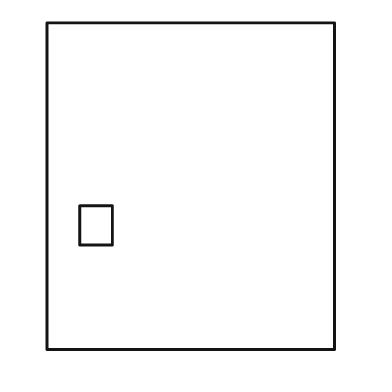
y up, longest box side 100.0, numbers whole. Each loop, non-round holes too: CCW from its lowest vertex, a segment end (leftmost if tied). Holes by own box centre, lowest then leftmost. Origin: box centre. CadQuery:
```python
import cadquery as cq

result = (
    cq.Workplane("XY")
    .moveTo(-44.0, -50.0)
    .lineTo(44.0, -50.0)
    .lineTo(44.0, 50.0)
    .lineTo(-44.0, 50.0)
    .close()
    .moveTo(-34.0, -18.0)
    .lineTo(-24.0, -18.0)
    .lineTo(-24.0, -6.0)
    .lineTo(-34.0, -6.0)
    .close()
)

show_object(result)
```